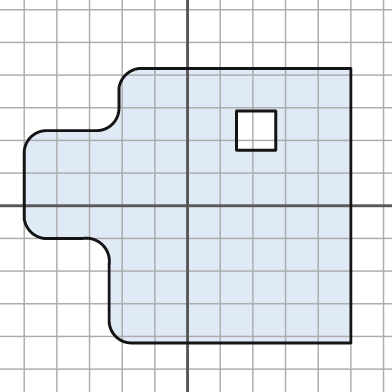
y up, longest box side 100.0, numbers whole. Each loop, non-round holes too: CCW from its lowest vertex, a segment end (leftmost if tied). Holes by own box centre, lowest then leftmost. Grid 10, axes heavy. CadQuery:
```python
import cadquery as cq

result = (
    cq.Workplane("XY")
    .moveTo(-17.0, -42.0)
    .lineTo(50.0, -42.0)
    .lineTo(50.0, 42.0)
    .lineTo(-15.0, 42.0)
    .threePointArc((-19.0, 40.0), (-21.0, 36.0))
    .lineTo(-21.0, 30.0)
    .threePointArc((-23.0, 25.0), (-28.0, 23.0))
    .lineTo(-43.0, 23.0)
    .threePointArc((-48.0, 21.0), (-50.0, 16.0))
    .lineTo(-50.0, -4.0)
    .threePointArc((-48.0, -8.0), (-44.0, -10.0))
    .lineTo(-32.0, -10.0)
    .threePointArc((-26.0, -12.0), (-24.0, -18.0))
    .lineTo(-24.0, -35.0)
    .threePointArc((-22.0, -40.0), (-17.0, -42.0))
    .close()
    .moveTo(15.0, 17.0)
    .lineTo(27.0, 17.0)
    .lineTo(27.0, 29.0)
    .lineTo(15.0, 29.0)
    .close()
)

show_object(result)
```